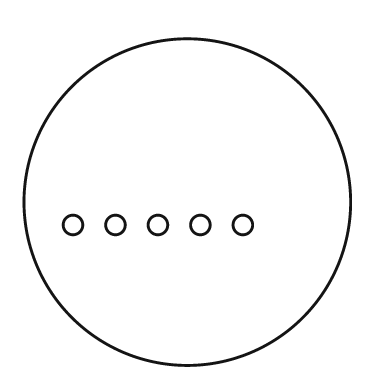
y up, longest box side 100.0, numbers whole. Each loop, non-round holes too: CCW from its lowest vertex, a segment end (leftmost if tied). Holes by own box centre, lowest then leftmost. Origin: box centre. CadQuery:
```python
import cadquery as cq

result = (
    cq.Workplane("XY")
    .moveTo(0.0, 0.0)
    .circle(50.0)
    .moveTo(-35.0, -7.0)
    .circle(3.0)
    .moveTo(-22.0, -7.0)
    .circle(3.0)
    .moveTo(-9.0, -7.0)
    .circle(3.0)
    .moveTo(4.0, -7.0)
    .circle(3.0)
    .moveTo(17.0, -7.0)
    .circle(3.0)
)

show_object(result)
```